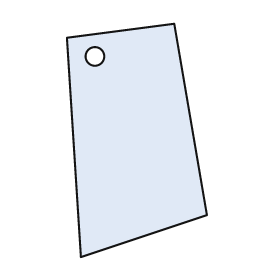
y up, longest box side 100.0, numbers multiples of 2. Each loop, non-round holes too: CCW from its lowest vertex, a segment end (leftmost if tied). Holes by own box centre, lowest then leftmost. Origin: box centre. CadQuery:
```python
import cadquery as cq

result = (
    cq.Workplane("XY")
    .moveTo(-24.0, -50.0)
    .lineTo(30.0, -32.0)
    .lineTo(16.0, 50.0)
    .lineTo(-30.0, 44.0)
    .close()
    .moveTo(-18.0, 36.0)
    .circle(4.0)
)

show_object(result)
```